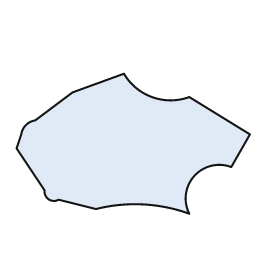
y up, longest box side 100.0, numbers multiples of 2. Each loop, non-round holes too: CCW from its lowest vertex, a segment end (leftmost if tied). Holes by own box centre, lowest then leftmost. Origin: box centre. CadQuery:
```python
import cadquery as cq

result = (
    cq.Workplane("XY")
    .moveTo(24.0, -30.0)
    .threePointArc((26.0, -14.0), (42.0, -10.0))
    .lineTo(50.0, 4.0)
    .lineTo(24.0, 20.0)
    .threePointArc((8.0, 20.0), (-4.0, 30.0))
    .lineTo(-26.0, 22.0)
    .lineTo(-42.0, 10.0)
    .threePointArc((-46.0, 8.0), (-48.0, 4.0))
    .lineTo(-50.0, -2.0)
    .lineTo(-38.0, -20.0)
    .threePointArc((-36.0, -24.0), (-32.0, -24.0))
    .lineTo(-16.0, -28.0)
    .threePointArc((4.0, -26.0), (24.0, -30.0))
    .close()
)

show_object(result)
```